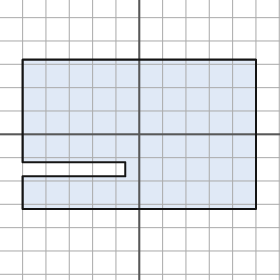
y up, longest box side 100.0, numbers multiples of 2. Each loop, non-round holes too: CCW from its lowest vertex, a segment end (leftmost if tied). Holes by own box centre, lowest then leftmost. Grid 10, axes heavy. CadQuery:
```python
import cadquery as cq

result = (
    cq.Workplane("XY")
    .moveTo(-50.0, -32.0)
    .lineTo(50.0, -32.0)
    .lineTo(50.0, 32.0)
    .lineTo(-50.0, 32.0)
    .lineTo(-50.0, -12.0)
    .lineTo(-6.0, -12.0)
    .lineTo(-6.0, -18.0)
    .lineTo(-50.0, -18.0)
    .close()
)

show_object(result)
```